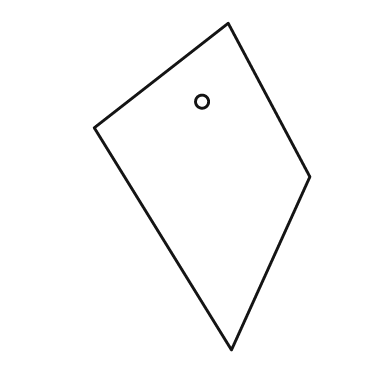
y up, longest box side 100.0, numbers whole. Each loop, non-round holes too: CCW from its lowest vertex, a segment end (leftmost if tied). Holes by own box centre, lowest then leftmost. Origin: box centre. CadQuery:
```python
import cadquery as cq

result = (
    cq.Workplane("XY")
    .moveTo(9.0, -50.0)
    .lineTo(33.0, 3.0)
    .lineTo(8.0, 50.0)
    .lineTo(-33.0, 18.0)
    .close()
    .moveTo(0.0, 26.0)
    .circle(2.0)
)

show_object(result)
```